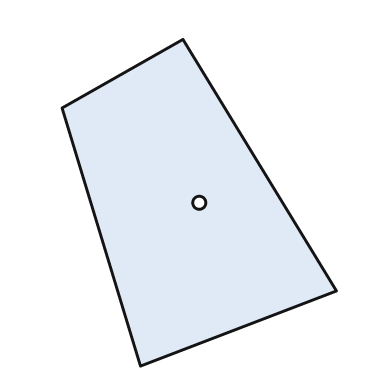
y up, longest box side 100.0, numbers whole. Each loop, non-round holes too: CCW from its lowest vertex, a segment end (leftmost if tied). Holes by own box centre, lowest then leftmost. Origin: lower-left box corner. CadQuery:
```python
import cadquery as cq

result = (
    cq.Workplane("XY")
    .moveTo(24.0, 0.0)
    .lineTo(84.0, 23.0)
    .lineTo(37.0, 100.0)
    .lineTo(0.0, 79.0)
    .close()
    .moveTo(42.0, 50.0)
    .circle(2.0)
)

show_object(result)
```